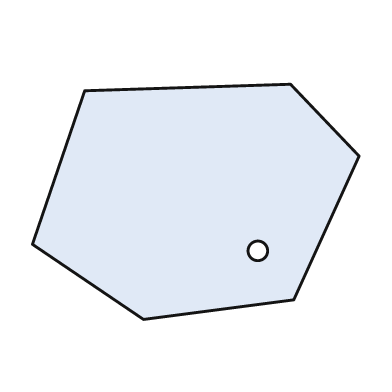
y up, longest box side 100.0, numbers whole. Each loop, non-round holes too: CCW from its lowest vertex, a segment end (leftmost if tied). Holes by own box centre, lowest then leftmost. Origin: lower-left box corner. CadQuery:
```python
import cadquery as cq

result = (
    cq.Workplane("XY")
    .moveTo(34.0, 0.0)
    .lineTo(80.0, 6.0)
    .lineTo(100.0, 50.0)
    .lineTo(79.0, 72.0)
    .lineTo(16.0, 70.0)
    .lineTo(0.0, 23.0)
    .close()
    .moveTo(69.0, 21.0)
    .circle(3.0)
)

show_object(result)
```